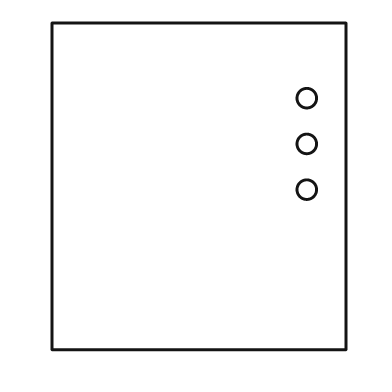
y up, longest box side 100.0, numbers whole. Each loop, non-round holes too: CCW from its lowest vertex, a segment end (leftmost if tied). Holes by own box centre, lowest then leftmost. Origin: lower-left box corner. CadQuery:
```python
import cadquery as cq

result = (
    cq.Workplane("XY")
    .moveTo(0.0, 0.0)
    .lineTo(90.0, 0.0)
    .lineTo(90.0, 100.0)
    .lineTo(0.0, 100.0)
    .close()
    .moveTo(78.0, 49.0)
    .circle(3.0)
    .moveTo(78.0, 63.0)
    .circle(3.0)
    .moveTo(78.0, 77.0)
    .circle(3.0)
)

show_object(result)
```